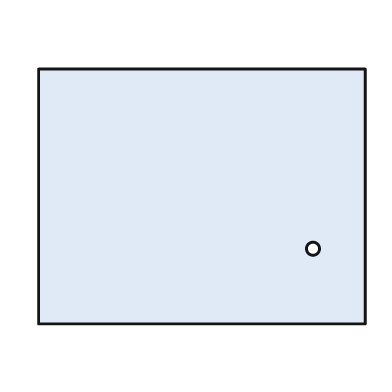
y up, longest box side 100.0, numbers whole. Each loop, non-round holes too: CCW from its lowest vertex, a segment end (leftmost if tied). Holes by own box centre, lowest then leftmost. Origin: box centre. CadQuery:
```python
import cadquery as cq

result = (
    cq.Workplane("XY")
    .moveTo(-50.0, -39.0)
    .lineTo(50.0, -39.0)
    .lineTo(50.0, 39.0)
    .lineTo(-50.0, 39.0)
    .close()
    .moveTo(34.0, -16.0)
    .circle(2.0)
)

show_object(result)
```